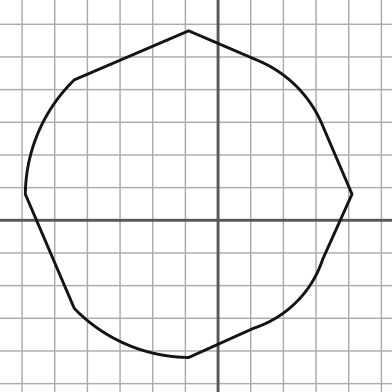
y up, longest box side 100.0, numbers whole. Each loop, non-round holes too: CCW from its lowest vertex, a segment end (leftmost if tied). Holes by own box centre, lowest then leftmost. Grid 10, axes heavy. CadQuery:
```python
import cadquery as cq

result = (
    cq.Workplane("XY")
    .moveTo(-9.0, -42.0)
    .lineTo(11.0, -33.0)
    .threePointArc((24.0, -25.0), (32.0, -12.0))
    .lineTo(41.0, 8.0)
    .lineTo(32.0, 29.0)
    .threePointArc((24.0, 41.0), (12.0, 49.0))
    .lineTo(-9.0, 58.0)
    .lineTo(-44.0, 43.0)
    .threePointArc((-55.0, 27.0), (-59.0, 8.0))
    .lineTo(-44.0, -27.0)
    .threePointArc((-28.0, -38.0), (-9.0, -42.0))
    .close()
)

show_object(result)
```